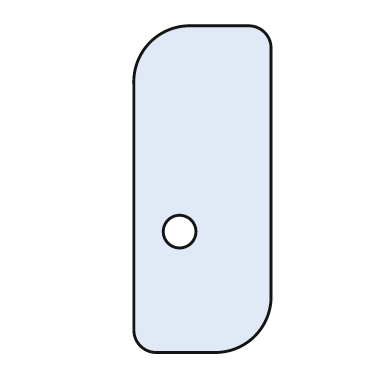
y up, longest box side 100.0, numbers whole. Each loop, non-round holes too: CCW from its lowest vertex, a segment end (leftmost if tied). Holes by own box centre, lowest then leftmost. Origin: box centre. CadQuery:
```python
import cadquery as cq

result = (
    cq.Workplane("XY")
    .moveTo(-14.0, -50.0)
    .lineTo(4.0, -50.0)
    .threePointArc((16.0, -45.0), (21.0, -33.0))
    .lineTo(21.0, 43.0)
    .threePointArc((19.0, 48.0), (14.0, 50.0))
    .lineTo(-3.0, 50.0)
    .threePointArc((-16.0, 45.0), (-21.0, 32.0))
    .lineTo(-21.0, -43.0)
    .threePointArc((-19.0, -48.0), (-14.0, -50.0))
    .close()
    .moveTo(-7.0, -13.0)
    .circle(5.0)
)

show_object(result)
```